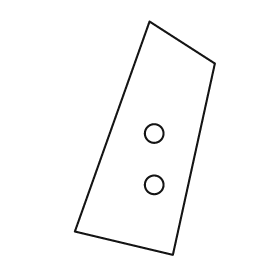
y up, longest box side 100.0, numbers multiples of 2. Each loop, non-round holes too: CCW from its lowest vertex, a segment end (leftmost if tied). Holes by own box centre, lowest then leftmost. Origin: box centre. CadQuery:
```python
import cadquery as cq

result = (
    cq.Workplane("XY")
    .moveTo(12.0, -50.0)
    .lineTo(30.0, 32.0)
    .lineTo(2.0, 50.0)
    .lineTo(-30.0, -40.0)
    .close()
    .moveTo(4.0, -20.0)
    .circle(4.0)
    .moveTo(4.0, 2.0)
    .circle(4.0)
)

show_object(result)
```